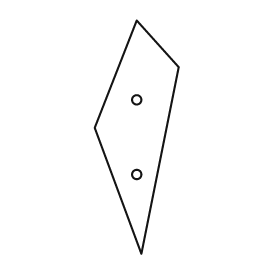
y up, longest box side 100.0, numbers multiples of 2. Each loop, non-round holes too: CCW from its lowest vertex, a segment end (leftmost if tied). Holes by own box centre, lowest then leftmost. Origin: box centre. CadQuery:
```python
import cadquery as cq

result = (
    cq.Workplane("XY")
    .moveTo(2.0, -50.0)
    .lineTo(18.0, 30.0)
    .lineTo(0.0, 50.0)
    .lineTo(-18.0, 4.0)
    .close()
    .moveTo(0.0, -16.0)
    .circle(2.0)
    .moveTo(0.0, 16.0)
    .circle(2.0)
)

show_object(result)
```